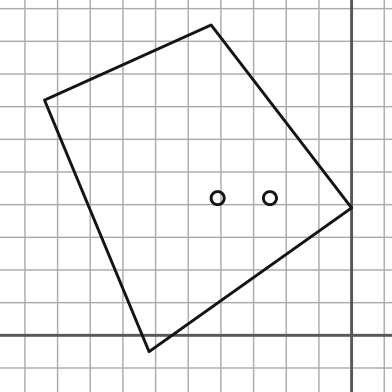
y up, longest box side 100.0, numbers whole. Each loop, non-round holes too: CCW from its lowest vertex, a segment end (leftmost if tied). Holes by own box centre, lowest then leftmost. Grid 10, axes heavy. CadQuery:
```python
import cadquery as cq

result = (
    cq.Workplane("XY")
    .moveTo(-62.0, -5.0)
    .lineTo(0.0, 39.0)
    .lineTo(-43.0, 95.0)
    .lineTo(-94.0, 72.0)
    .close()
    .moveTo(-41.0, 42.0)
    .circle(2.0)
    .moveTo(-25.0, 42.0)
    .circle(2.0)
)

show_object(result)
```